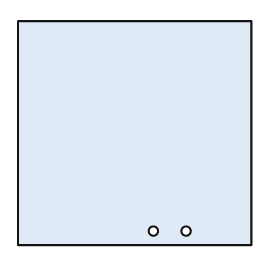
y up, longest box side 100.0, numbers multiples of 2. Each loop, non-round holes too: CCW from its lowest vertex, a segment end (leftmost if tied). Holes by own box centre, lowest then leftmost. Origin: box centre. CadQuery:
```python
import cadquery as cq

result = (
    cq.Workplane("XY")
    .moveTo(-50.0, -48.0)
    .lineTo(50.0, -48.0)
    .lineTo(50.0, 48.0)
    .lineTo(-50.0, 48.0)
    .close()
    .moveTo(8.0, -42.0)
    .circle(2.0)
    .moveTo(22.0, -42.0)
    .circle(2.0)
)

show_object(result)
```